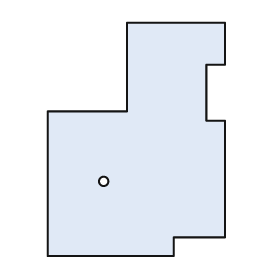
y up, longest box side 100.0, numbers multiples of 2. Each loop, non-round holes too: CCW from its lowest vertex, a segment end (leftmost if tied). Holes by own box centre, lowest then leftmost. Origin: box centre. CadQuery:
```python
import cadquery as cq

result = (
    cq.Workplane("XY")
    .moveTo(-38.0, -50.0)
    .lineTo(16.0, -50.0)
    .lineTo(16.0, -42.0)
    .lineTo(38.0, -42.0)
    .lineTo(38.0, 8.0)
    .lineTo(30.0, 8.0)
    .lineTo(30.0, 32.0)
    .lineTo(38.0, 32.0)
    .lineTo(38.0, 50.0)
    .lineTo(-4.0, 50.0)
    .lineTo(-4.0, 12.0)
    .lineTo(-38.0, 12.0)
    .close()
    .moveTo(-14.0, -18.0)
    .circle(2.0)
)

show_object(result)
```